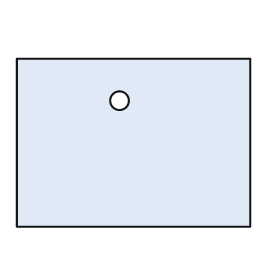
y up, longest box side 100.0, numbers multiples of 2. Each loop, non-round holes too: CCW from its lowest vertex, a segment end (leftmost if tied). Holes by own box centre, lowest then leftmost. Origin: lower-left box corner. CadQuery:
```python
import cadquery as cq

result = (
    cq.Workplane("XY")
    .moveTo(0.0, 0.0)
    .lineTo(100.0, 0.0)
    .lineTo(100.0, 72.0)
    .lineTo(0.0, 72.0)
    .close()
    .moveTo(44.0, 54.0)
    .circle(4.0)
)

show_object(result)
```